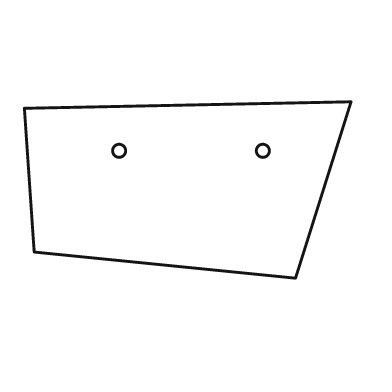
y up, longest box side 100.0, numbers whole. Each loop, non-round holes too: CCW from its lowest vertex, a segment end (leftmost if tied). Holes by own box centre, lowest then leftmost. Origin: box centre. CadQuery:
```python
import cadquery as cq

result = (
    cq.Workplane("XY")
    .moveTo(33.0, -27.0)
    .lineTo(50.0, 27.0)
    .lineTo(-50.0, 25.0)
    .lineTo(-47.0, -19.0)
    .close()
    .moveTo(-21.0, 12.0)
    .circle(2.0)
    .moveTo(23.0, 12.0)
    .circle(2.0)
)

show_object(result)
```